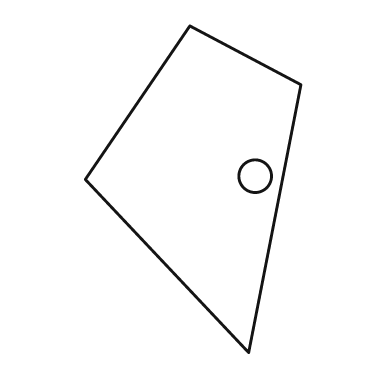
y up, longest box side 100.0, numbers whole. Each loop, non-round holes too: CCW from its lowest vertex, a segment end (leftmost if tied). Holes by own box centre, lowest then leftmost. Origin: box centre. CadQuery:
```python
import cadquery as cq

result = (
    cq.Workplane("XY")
    .moveTo(17.0, -50.0)
    .lineTo(33.0, 32.0)
    .lineTo(-1.0, 50.0)
    .lineTo(-33.0, 3.0)
    .close()
    .moveTo(19.0, 4.0)
    .circle(5.0)
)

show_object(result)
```